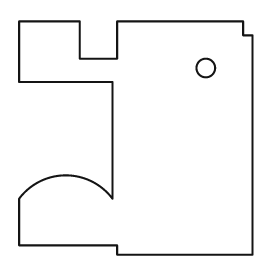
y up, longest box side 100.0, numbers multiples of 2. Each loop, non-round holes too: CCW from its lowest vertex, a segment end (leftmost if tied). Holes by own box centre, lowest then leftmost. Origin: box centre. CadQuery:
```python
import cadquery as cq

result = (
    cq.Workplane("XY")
    .moveTo(-8.0, -50.0)
    .lineTo(50.0, -50.0)
    .lineTo(50.0, 44.0)
    .lineTo(46.0, 44.0)
    .lineTo(46.0, 50.0)
    .lineTo(-8.0, 50.0)
    .lineTo(-8.0, 34.0)
    .lineTo(-24.0, 34.0)
    .lineTo(-24.0, 50.0)
    .lineTo(-50.0, 50.0)
    .lineTo(-50.0, 24.0)
    .lineTo(-10.0, 24.0)
    .lineTo(-10.0, -26.0)
    .threePointArc((-30.0, -16.0), (-50.0, -26.0))
    .lineTo(-50.0, -46.0)
    .lineTo(-8.0, -46.0)
    .close()
    .moveTo(30.0, 30.0)
    .circle(4.0)
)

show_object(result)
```